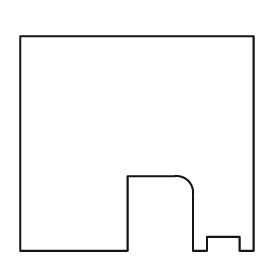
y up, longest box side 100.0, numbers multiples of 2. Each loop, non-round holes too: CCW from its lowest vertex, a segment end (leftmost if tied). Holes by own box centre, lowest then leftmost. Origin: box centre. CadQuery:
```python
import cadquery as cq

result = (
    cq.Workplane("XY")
    .moveTo(-50.0, -46.0)
    .lineTo(-4.0, -46.0)
    .lineTo(-4.0, -14.0)
    .lineTo(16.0, -14.0)
    .threePointArc((22.0, -16.0), (24.0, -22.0))
    .lineTo(24.0, -46.0)
    .lineTo(30.0, -46.0)
    .lineTo(30.0, -40.0)
    .lineTo(44.0, -40.0)
    .lineTo(44.0, -46.0)
    .lineTo(50.0, -46.0)
    .lineTo(50.0, 46.0)
    .lineTo(-50.0, 46.0)
    .close()
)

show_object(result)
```